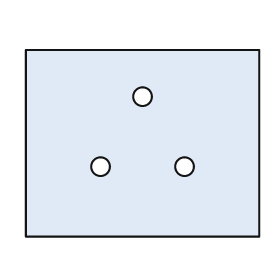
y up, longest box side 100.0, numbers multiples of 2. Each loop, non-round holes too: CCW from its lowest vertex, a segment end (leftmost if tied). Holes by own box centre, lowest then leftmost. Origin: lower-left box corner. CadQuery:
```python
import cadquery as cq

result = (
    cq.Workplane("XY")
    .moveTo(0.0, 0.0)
    .lineTo(100.0, 0.0)
    .lineTo(100.0, 80.0)
    .lineTo(0.0, 80.0)
    .close()
    .moveTo(32.0, 30.0)
    .circle(4.0)
    .moveTo(68.0, 30.0)
    .circle(4.0)
    .moveTo(50.0, 60.0)
    .circle(4.0)
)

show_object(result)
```